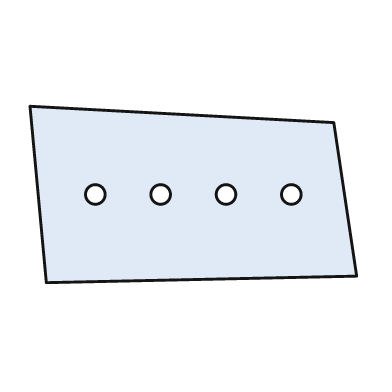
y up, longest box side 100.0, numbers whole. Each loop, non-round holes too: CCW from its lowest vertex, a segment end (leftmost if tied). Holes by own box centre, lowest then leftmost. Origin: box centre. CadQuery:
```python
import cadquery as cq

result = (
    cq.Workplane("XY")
    .moveTo(-45.0, -27.0)
    .lineTo(50.0, -25.0)
    .lineTo(43.0, 22.0)
    .lineTo(-50.0, 27.0)
    .close()
    .moveTo(-30.0, 0.0)
    .circle(3.0)
    .moveTo(-10.0, 0.0)
    .circle(3.0)
    .moveTo(10.0, 0.0)
    .circle(3.0)
    .moveTo(30.0, 0.0)
    .circle(3.0)
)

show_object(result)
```